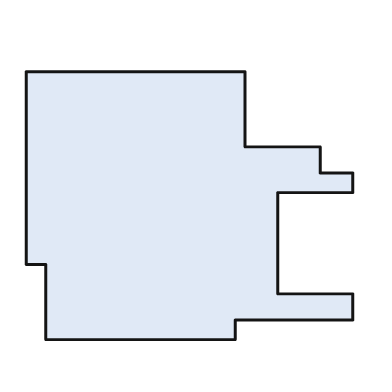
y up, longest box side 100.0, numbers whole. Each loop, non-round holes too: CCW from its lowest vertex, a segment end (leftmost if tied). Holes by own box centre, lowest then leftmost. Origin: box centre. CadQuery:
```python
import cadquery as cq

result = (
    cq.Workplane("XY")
    .moveTo(-44.0, -41.0)
    .lineTo(14.0, -41.0)
    .lineTo(14.0, -35.0)
    .lineTo(50.0, -35.0)
    .lineTo(50.0, -27.0)
    .lineTo(27.0, -27.0)
    .lineTo(27.0, 4.0)
    .lineTo(50.0, 4.0)
    .lineTo(50.0, 10.0)
    .lineTo(40.0, 10.0)
    .lineTo(40.0, 18.0)
    .lineTo(17.0, 18.0)
    .lineTo(17.0, 41.0)
    .lineTo(-50.0, 41.0)
    .lineTo(-50.0, -18.0)
    .lineTo(-44.0, -18.0)
    .close()
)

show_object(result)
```